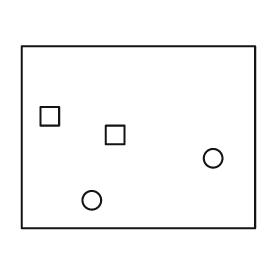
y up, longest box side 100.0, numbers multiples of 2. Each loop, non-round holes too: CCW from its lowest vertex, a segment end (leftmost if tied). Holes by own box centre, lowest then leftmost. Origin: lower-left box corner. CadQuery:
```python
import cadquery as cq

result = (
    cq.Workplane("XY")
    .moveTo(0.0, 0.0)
    .lineTo(100.0, 0.0)
    .lineTo(100.0, 78.0)
    .lineTo(0.0, 78.0)
    .close()
    .moveTo(30.0, 12.0)
    .circle(4.0)
    .moveTo(82.0, 30.0)
    .circle(4.0)
    .moveTo(36.0, 36.0)
    .lineTo(44.0, 36.0)
    .lineTo(44.0, 44.0)
    .lineTo(36.0, 44.0)
    .close()
    .moveTo(8.0, 44.0)
    .lineTo(16.0, 44.0)
    .lineTo(16.0, 52.0)
    .lineTo(8.0, 52.0)
    .close()
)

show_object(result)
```